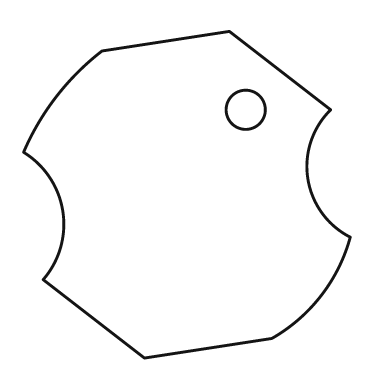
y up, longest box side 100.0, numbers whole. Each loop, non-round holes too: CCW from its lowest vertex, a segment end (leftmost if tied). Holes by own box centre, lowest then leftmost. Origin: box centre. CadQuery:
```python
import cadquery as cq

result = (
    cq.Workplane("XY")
    .moveTo(-13.0, -50.0)
    .lineTo(26.0, -44.0)
    .threePointArc((41.0, -31.0), (50.0, -13.0))
    .threePointArc((37.0, 5.0), (44.0, 26.0))
    .lineTo(13.0, 50.0)
    .lineTo(-26.0, 44.0)
    .threePointArc((-40.0, 30.0), (-50.0, 13.0))
    .threePointArc((-38.0, -5.0), (-44.0, -26.0))
    .close()
    .moveTo(18.0, 26.0)
    .circle(6.0)
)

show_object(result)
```